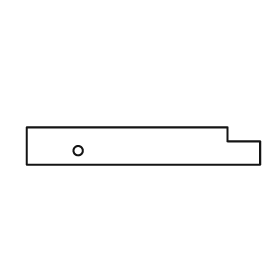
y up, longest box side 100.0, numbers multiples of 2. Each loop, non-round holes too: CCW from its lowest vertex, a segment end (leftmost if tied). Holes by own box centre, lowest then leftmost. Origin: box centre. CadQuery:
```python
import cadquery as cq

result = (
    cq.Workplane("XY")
    .moveTo(-50.0, -8.0)
    .lineTo(50.0, -8.0)
    .lineTo(50.0, 2.0)
    .lineTo(36.0, 2.0)
    .lineTo(36.0, 8.0)
    .lineTo(-50.0, 8.0)
    .close()
    .moveTo(-28.0, -2.0)
    .circle(2.0)
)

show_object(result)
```